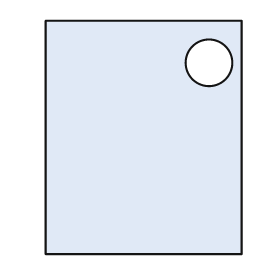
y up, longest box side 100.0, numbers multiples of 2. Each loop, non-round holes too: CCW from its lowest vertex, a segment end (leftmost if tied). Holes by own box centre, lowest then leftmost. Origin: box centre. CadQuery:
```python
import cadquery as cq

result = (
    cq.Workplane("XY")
    .moveTo(-42.0, -50.0)
    .lineTo(42.0, -50.0)
    .lineTo(42.0, 50.0)
    .lineTo(-42.0, 50.0)
    .close()
    .moveTo(28.0, 32.0)
    .circle(10.0)
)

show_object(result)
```